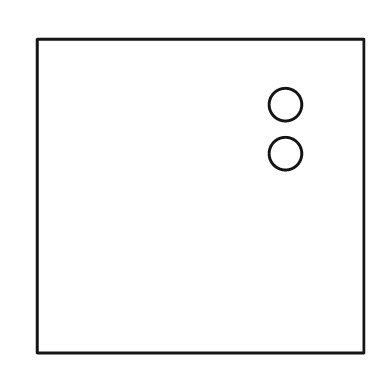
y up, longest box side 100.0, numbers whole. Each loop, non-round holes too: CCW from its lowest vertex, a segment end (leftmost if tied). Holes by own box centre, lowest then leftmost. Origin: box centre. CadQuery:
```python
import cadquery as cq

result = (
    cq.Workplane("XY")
    .moveTo(-50.0, -48.0)
    .lineTo(50.0, -48.0)
    .lineTo(50.0, 48.0)
    .lineTo(-50.0, 48.0)
    .close()
    .moveTo(26.0, 13.0)
    .circle(5.0)
    .moveTo(26.0, 28.0)
    .circle(5.0)
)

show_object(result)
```